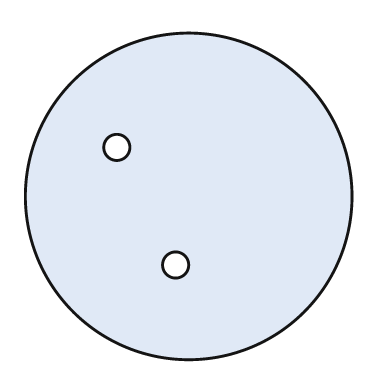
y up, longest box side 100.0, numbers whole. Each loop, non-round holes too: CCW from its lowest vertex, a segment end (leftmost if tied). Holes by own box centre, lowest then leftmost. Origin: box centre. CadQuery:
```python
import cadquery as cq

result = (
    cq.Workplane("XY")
    .moveTo(0.0, 0.0)
    .circle(50.0)
    .moveTo(-4.0, -21.0)
    .circle(4.0)
    .moveTo(-22.0, 15.0)
    .circle(4.0)
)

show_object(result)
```